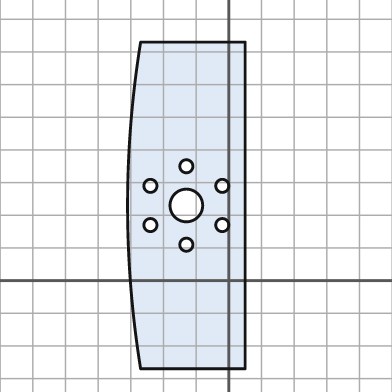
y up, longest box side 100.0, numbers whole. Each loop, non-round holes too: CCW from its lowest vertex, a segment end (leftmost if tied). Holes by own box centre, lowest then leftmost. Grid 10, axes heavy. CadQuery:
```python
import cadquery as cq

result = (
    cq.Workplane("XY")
    .moveTo(-27.0, -27.0)
    .lineTo(5.0, -27.0)
    .lineTo(5.0, 73.0)
    .lineTo(-27.0, 73.0)
    .threePointArc((-31.0, 23.0), (-27.0, -27.0))
    .close()
    .moveTo(-13.0, 11.0)
    .circle(2.0)
    .moveTo(-24.0, 17.0)
    .circle(2.0)
    .moveTo(-2.0, 17.0)
    .circle(2.0)
    .moveTo(-13.0, 23.0)
    .circle(5.0)
    .moveTo(-24.0, 29.0)
    .circle(2.0)
    .moveTo(-2.0, 29.0)
    .circle(2.0)
    .moveTo(-13.0, 35.0)
    .circle(2.0)
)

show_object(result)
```